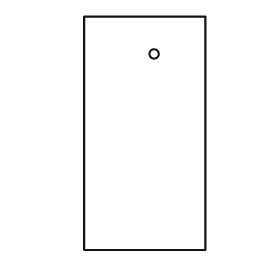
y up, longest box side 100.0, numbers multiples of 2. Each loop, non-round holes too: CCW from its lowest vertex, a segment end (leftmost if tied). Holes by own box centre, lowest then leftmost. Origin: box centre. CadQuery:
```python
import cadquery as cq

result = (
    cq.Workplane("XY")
    .moveTo(-26.0, -50.0)
    .lineTo(26.0, -50.0)
    .lineTo(26.0, 50.0)
    .lineTo(-26.0, 50.0)
    .close()
    .moveTo(4.0, 34.0)
    .circle(2.0)
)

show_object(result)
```